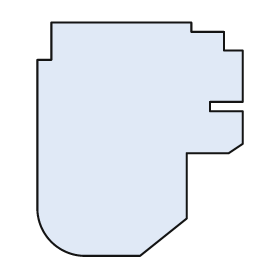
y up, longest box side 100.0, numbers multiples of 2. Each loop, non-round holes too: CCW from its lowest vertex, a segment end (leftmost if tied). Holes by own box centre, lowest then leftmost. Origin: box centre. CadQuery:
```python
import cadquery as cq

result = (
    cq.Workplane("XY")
    .moveTo(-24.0, -50.0)
    .lineTo(0.0, -50.0)
    .lineTo(20.0, -34.0)
    .lineTo(20.0, -6.0)
    .lineTo(38.0, -6.0)
    .lineTo(44.0, -2.0)
    .lineTo(44.0, 12.0)
    .lineTo(30.0, 12.0)
    .lineTo(30.0, 16.0)
    .lineTo(44.0, 16.0)
    .lineTo(44.0, 38.0)
    .lineTo(36.0, 38.0)
    .lineTo(36.0, 46.0)
    .lineTo(22.0, 46.0)
    .lineTo(22.0, 50.0)
    .lineTo(-38.0, 50.0)
    .lineTo(-38.0, 34.0)
    .lineTo(-44.0, 34.0)
    .lineTo(-44.0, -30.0)
    .threePointArc((-38.0, -44.0), (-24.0, -50.0))
    .close()
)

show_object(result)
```